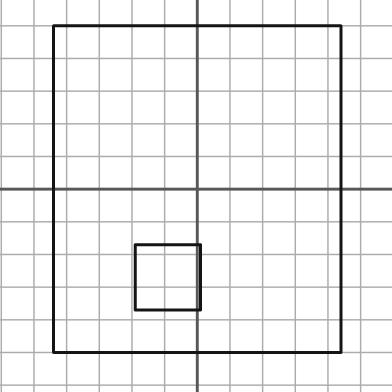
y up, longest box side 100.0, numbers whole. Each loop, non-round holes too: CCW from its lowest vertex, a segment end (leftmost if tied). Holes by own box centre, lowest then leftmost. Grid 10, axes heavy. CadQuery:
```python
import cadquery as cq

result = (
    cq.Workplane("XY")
    .moveTo(-44.0, -50.0)
    .lineTo(44.0, -50.0)
    .lineTo(44.0, 50.0)
    .lineTo(-44.0, 50.0)
    .close()
    .moveTo(-19.0, -37.0)
    .lineTo(1.0, -37.0)
    .lineTo(1.0, -17.0)
    .lineTo(-19.0, -17.0)
    .close()
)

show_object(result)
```